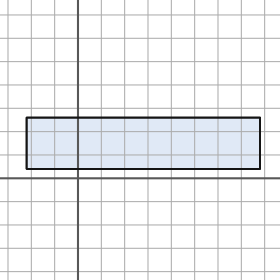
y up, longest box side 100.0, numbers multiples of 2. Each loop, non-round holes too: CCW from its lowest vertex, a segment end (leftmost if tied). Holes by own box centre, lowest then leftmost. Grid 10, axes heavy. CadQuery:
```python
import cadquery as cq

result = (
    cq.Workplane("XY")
    .moveTo(-22.0, 4.0)
    .lineTo(78.0, 4.0)
    .lineTo(78.0, 26.0)
    .lineTo(-22.0, 26.0)
    .close()
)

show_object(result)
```